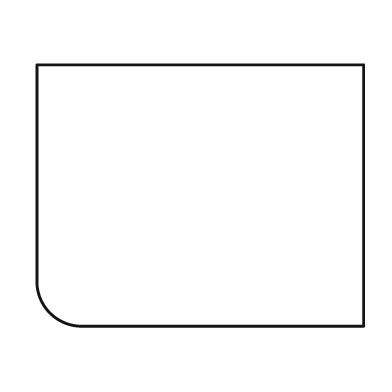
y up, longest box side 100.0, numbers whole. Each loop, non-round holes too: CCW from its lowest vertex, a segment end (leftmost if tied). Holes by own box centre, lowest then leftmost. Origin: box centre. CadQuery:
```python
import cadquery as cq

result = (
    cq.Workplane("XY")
    .moveTo(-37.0, -40.0)
    .lineTo(50.0, -40.0)
    .lineTo(50.0, 40.0)
    .lineTo(-50.0, 40.0)
    .lineTo(-50.0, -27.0)
    .threePointArc((-46.0, -36.0), (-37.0, -40.0))
    .close()
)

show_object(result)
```